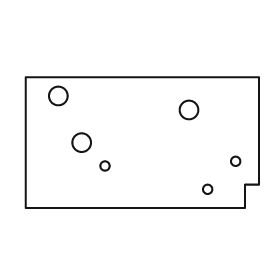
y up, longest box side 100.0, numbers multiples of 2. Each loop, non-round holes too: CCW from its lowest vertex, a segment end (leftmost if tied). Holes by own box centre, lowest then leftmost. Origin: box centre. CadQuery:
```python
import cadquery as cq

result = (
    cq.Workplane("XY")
    .moveTo(-50.0, -28.0)
    .lineTo(44.0, -28.0)
    .lineTo(44.0, -18.0)
    .lineTo(50.0, -18.0)
    .lineTo(50.0, 28.0)
    .lineTo(-50.0, 28.0)
    .close()
    .moveTo(28.0, -20.0)
    .circle(2.0)
    .moveTo(-16.0, -10.0)
    .circle(2.0)
    .moveTo(40.0, -8.0)
    .circle(2.0)
    .moveTo(-26.0, 0.0)
    .circle(4.0)
    .moveTo(20.0, 14.0)
    .circle(4.0)
    .moveTo(-36.0, 20.0)
    .circle(4.0)
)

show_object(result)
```